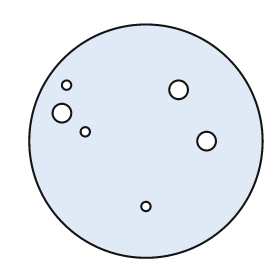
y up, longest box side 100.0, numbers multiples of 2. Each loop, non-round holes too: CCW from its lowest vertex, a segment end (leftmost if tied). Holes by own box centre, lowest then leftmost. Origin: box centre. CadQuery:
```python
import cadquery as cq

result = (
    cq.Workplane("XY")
    .moveTo(0.0, 0.0)
    .circle(50.0)
    .moveTo(0.0, -28.0)
    .circle(2.0)
    .moveTo(26.0, 0.0)
    .circle(4.0)
    .moveTo(-26.0, 4.0)
    .circle(2.0)
    .moveTo(-36.0, 12.0)
    .circle(4.0)
    .moveTo(14.0, 22.0)
    .circle(4.0)
    .moveTo(-34.0, 24.0)
    .circle(2.0)
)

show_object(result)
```